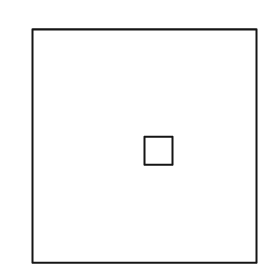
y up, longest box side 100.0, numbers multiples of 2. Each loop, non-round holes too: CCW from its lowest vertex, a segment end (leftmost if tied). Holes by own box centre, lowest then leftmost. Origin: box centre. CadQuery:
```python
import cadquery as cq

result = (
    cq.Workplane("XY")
    .moveTo(-48.0, -50.0)
    .lineTo(48.0, -50.0)
    .lineTo(48.0, 50.0)
    .lineTo(-48.0, 50.0)
    .close()
    .moveTo(0.0, -8.0)
    .lineTo(12.0, -8.0)
    .lineTo(12.0, 4.0)
    .lineTo(0.0, 4.0)
    .close()
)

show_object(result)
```